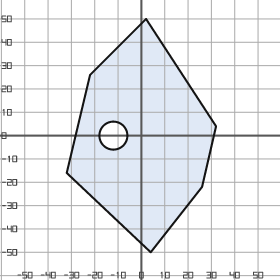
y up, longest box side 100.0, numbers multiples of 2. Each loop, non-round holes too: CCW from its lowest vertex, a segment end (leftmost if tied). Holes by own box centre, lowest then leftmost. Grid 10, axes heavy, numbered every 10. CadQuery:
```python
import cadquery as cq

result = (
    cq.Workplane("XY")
    .moveTo(4.0, -50.0)
    .lineTo(26.0, -22.0)
    .lineTo(32.0, 4.0)
    .lineTo(2.0, 50.0)
    .lineTo(-22.0, 26.0)
    .lineTo(-32.0, -16.0)
    .close()
    .moveTo(-12.0, 0.0)
    .circle(6.0)
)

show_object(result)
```